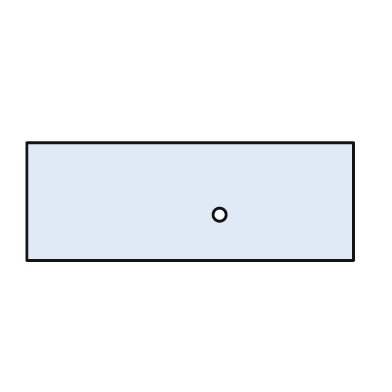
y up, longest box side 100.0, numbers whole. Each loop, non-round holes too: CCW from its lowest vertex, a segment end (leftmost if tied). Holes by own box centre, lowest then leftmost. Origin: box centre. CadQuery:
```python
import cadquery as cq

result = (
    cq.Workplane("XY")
    .moveTo(-50.0, -18.0)
    .lineTo(50.0, -18.0)
    .lineTo(50.0, 18.0)
    .lineTo(-50.0, 18.0)
    .close()
    .moveTo(9.0, -4.0)
    .circle(2.0)
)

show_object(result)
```